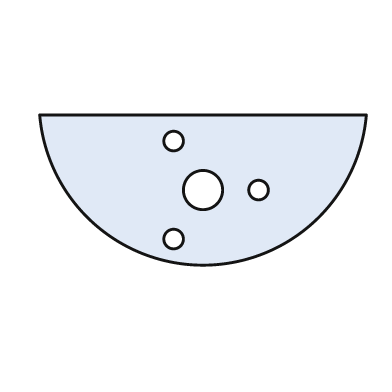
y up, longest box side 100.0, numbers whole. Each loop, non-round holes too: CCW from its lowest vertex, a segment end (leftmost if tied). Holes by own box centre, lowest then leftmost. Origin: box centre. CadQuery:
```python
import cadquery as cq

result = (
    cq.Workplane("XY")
    .moveTo(-50.0, 23.0)
    .threePointArc((0.0, -23.0), (50.0, 23.0))
    .close()
    .moveTo(-9.0, -15.0)
    .circle(3.0)
    .moveTo(0.0, 0.0)
    .circle(6.0)
    .moveTo(17.0, 0.0)
    .circle(3.0)
    .moveTo(-9.0, 15.0)
    .circle(3.0)
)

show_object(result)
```